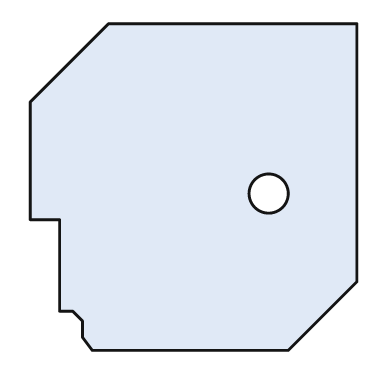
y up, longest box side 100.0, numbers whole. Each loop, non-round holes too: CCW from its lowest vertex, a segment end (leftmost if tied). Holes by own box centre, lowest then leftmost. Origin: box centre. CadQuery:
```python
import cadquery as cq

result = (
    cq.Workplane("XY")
    .moveTo(-31.0, -50.0)
    .lineTo(29.0, -50.0)
    .lineTo(50.0, -29.0)
    .lineTo(50.0, 50.0)
    .lineTo(-26.0, 50.0)
    .lineTo(-50.0, 26.0)
    .lineTo(-50.0, -10.0)
    .lineTo(-41.0, -10.0)
    .lineTo(-41.0, -38.0)
    .lineTo(-37.0, -38.0)
    .lineTo(-34.0, -41.0)
    .lineTo(-34.0, -46.0)
    .close()
    .moveTo(23.0, -2.0)
    .circle(6.0)
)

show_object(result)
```